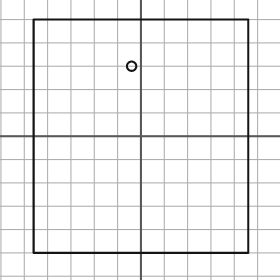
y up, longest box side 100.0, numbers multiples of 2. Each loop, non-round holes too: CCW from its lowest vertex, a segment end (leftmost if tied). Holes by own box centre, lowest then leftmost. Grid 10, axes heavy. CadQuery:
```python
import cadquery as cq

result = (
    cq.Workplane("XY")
    .moveTo(-46.0, -50.0)
    .lineTo(46.0, -50.0)
    .lineTo(46.0, 50.0)
    .lineTo(-46.0, 50.0)
    .close()
    .moveTo(-4.0, 30.0)
    .circle(2.0)
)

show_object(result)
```